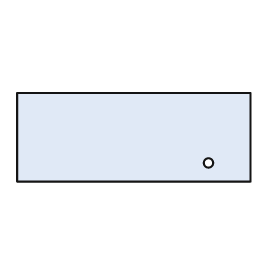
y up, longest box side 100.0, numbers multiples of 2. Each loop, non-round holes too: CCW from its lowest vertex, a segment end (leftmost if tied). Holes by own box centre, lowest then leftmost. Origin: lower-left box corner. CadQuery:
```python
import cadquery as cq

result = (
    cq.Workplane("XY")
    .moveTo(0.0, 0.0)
    .lineTo(100.0, 0.0)
    .lineTo(100.0, 38.0)
    .lineTo(0.0, 38.0)
    .close()
    .moveTo(82.0, 8.0)
    .circle(2.0)
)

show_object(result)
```